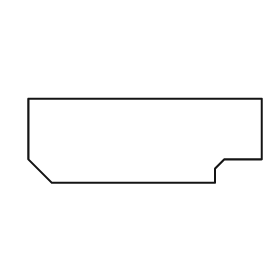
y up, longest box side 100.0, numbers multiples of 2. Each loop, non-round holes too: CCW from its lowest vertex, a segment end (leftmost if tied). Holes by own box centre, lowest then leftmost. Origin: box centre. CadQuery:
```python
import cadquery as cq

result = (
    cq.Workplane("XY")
    .moveTo(-40.0, -18.0)
    .lineTo(30.0, -18.0)
    .lineTo(30.0, -12.0)
    .lineTo(34.0, -8.0)
    .lineTo(50.0, -8.0)
    .lineTo(50.0, 18.0)
    .lineTo(-50.0, 18.0)
    .lineTo(-50.0, -8.0)
    .close()
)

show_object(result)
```